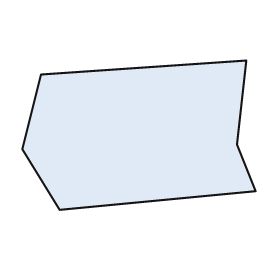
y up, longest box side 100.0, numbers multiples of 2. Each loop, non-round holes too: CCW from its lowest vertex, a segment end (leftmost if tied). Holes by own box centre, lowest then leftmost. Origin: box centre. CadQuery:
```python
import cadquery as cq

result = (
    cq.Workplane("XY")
    .moveTo(-34.0, -32.0)
    .lineTo(50.0, -24.0)
    .lineTo(42.0, -4.0)
    .lineTo(46.0, 32.0)
    .lineTo(-42.0, 26.0)
    .lineTo(-50.0, -6.0)
    .close()
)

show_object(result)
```